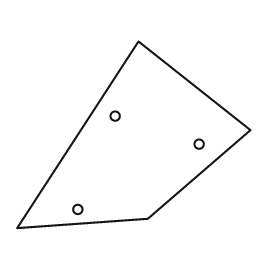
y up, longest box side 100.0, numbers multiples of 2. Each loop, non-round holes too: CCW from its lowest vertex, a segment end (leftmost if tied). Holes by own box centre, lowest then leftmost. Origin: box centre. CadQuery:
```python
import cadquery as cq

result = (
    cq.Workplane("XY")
    .moveTo(-50.0, -40.0)
    .lineTo(6.0, -36.0)
    .lineTo(50.0, 2.0)
    .lineTo(2.0, 40.0)
    .close()
    .moveTo(-24.0, -32.0)
    .circle(2.0)
    .moveTo(28.0, -4.0)
    .circle(2.0)
    .moveTo(-8.0, 8.0)
    .circle(2.0)
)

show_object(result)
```